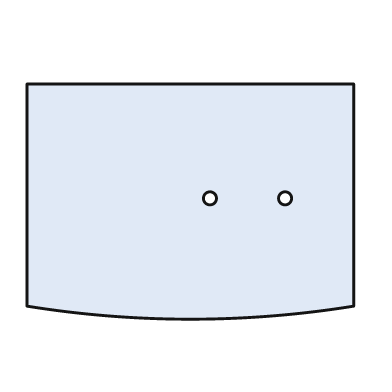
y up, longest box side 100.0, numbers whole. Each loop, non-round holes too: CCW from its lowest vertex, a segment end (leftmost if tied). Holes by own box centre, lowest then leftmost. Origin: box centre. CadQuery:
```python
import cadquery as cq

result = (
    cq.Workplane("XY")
    .moveTo(-50.0, -32.0)
    .threePointArc((0.0, -36.0), (50.0, -32.0))
    .lineTo(50.0, 36.0)
    .lineTo(-50.0, 36.0)
    .close()
    .moveTo(6.0, 1.0)
    .circle(2.0)
    .moveTo(29.0, 1.0)
    .circle(2.0)
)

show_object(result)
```